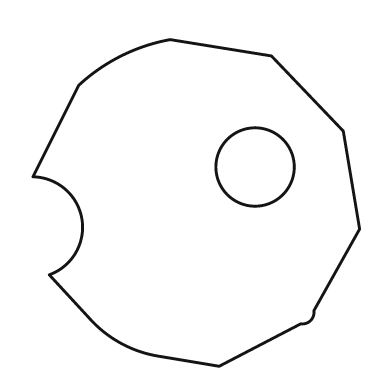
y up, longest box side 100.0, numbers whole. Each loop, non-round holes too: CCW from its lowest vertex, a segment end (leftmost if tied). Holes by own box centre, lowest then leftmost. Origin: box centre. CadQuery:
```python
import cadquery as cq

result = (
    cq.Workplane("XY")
    .moveTo(7.0, -50.0)
    .lineTo(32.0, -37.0)
    .threePointArc((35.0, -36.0), (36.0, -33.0))
    .lineTo(50.0, -8.0)
    .lineTo(45.0, 22.0)
    .lineTo(23.0, 45.0)
    .lineTo(-8.0, 50.0)
    .threePointArc((-23.0, 45.0), (-36.0, 36.0))
    .lineTo(-50.0, 8.0)
    .threePointArc((-35.0, -5.0), (-45.0, -22.0))
    .lineTo(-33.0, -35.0)
    .threePointArc((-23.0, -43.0), (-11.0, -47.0))
    .close()
    .moveTo(18.0, 11.0)
    .circle(12.0)
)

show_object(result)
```